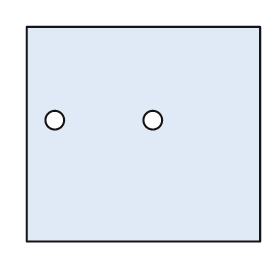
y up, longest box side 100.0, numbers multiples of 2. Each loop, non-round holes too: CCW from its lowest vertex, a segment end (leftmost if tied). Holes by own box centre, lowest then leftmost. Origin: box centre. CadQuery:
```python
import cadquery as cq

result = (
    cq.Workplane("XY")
    .moveTo(-50.0, -46.0)
    .lineTo(50.0, -46.0)
    .lineTo(50.0, 46.0)
    .lineTo(-50.0, 46.0)
    .close()
    .moveTo(-38.0, 6.0)
    .circle(4.0)
    .moveTo(4.0, 6.0)
    .circle(4.0)
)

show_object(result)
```